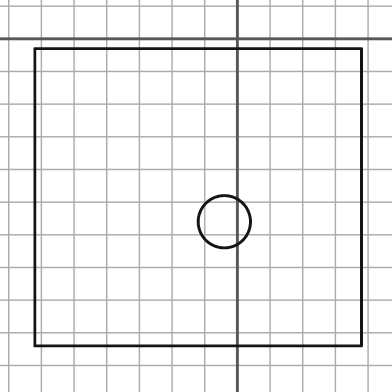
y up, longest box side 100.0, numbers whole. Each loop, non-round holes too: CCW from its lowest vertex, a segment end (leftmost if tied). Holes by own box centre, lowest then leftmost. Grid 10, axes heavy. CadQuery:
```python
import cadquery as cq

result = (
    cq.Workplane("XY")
    .moveTo(-62.0, -94.0)
    .lineTo(38.0, -94.0)
    .lineTo(38.0, -3.0)
    .lineTo(-62.0, -3.0)
    .close()
    .moveTo(-4.0, -56.0)
    .circle(8.0)
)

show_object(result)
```